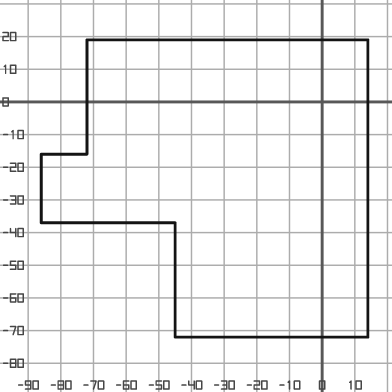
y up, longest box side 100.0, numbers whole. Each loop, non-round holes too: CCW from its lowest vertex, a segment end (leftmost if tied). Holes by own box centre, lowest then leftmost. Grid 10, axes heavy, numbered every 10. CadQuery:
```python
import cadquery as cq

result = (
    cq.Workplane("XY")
    .moveTo(-45.0, -72.0)
    .lineTo(14.0, -72.0)
    .lineTo(14.0, 19.0)
    .lineTo(-72.0, 19.0)
    .lineTo(-72.0, -16.0)
    .lineTo(-86.0, -16.0)
    .lineTo(-86.0, -37.0)
    .lineTo(-45.0, -37.0)
    .close()
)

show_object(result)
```